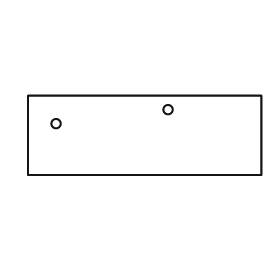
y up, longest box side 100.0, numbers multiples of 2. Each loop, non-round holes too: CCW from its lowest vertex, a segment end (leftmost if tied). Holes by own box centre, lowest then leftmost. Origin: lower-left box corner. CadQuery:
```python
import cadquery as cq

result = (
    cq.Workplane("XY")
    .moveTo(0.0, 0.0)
    .lineTo(100.0, 0.0)
    .lineTo(100.0, 34.0)
    .lineTo(0.0, 34.0)
    .close()
    .moveTo(12.0, 22.0)
    .circle(2.0)
    .moveTo(60.0, 28.0)
    .circle(2.0)
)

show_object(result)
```